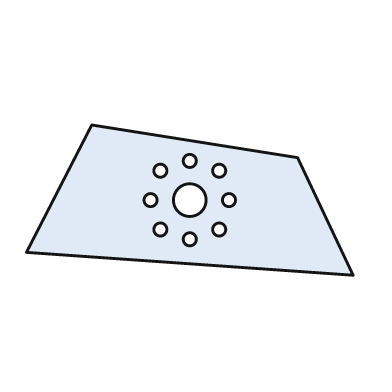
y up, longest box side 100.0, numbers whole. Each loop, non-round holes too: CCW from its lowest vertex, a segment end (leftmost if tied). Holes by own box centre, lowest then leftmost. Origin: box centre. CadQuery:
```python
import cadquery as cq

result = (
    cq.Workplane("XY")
    .moveTo(50.0, -23.0)
    .lineTo(33.0, 13.0)
    .lineTo(-30.0, 23.0)
    .lineTo(-50.0, -16.0)
    .close()
    .moveTo(0.0, -12.0)
    .circle(2.0)
    .moveTo(-9.0, -9.0)
    .circle(2.0)
    .moveTo(9.0, -9.0)
    .circle(2.0)
    .moveTo(-12.0, 0.0)
    .circle(2.0)
    .moveTo(0.0, 0.0)
    .circle(5.0)
    .moveTo(12.0, 0.0)
    .circle(2.0)
    .moveTo(-9.0, 9.0)
    .circle(2.0)
    .moveTo(9.0, 9.0)
    .circle(2.0)
    .moveTo(0.0, 12.0)
    .circle(2.0)
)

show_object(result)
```